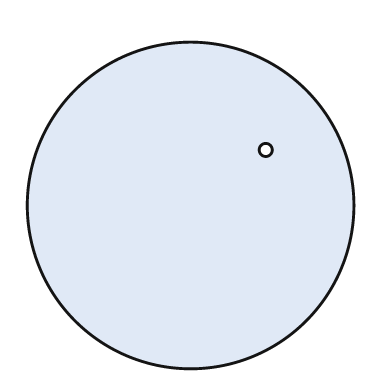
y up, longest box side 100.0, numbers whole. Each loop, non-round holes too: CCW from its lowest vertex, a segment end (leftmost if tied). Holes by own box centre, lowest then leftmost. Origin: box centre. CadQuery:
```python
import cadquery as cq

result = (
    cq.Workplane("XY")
    .moveTo(0.0, 0.0)
    .circle(50.0)
    .moveTo(23.0, 17.0)
    .circle(2.0)
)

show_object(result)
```